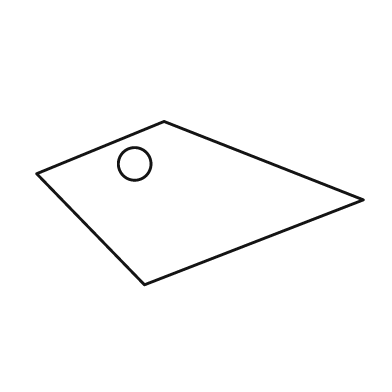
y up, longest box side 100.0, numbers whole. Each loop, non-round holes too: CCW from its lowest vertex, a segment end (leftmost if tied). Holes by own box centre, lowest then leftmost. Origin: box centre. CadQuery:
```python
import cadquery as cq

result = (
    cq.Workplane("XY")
    .moveTo(-17.0, -25.0)
    .lineTo(50.0, 1.0)
    .lineTo(-11.0, 25.0)
    .lineTo(-50.0, 9.0)
    .close()
    .moveTo(-20.0, 12.0)
    .circle(5.0)
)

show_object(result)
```